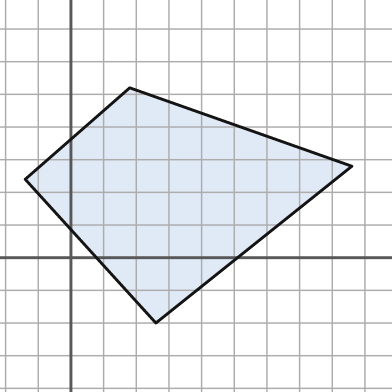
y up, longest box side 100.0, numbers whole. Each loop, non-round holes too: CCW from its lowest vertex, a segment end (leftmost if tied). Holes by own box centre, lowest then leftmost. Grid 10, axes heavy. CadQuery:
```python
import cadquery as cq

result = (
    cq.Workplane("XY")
    .moveTo(26.0, -20.0)
    .lineTo(86.0, 28.0)
    .lineTo(18.0, 52.0)
    .lineTo(-14.0, 24.0)
    .close()
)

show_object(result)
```